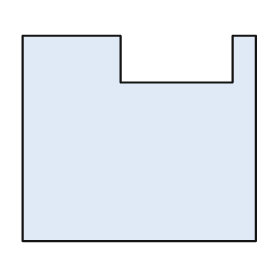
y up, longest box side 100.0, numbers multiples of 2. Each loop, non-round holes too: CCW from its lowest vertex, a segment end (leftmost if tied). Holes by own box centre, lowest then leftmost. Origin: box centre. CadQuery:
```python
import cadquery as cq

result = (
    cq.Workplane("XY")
    .moveTo(-50.0, -44.0)
    .lineTo(50.0, -44.0)
    .lineTo(50.0, 44.0)
    .lineTo(40.0, 44.0)
    .lineTo(40.0, 24.0)
    .lineTo(-8.0, 24.0)
    .lineTo(-8.0, 44.0)
    .lineTo(-50.0, 44.0)
    .close()
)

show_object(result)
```